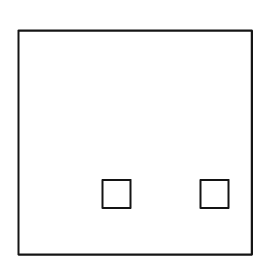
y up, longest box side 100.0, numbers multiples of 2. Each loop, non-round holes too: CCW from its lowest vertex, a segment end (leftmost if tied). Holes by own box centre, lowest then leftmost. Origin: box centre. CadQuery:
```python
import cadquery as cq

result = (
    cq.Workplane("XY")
    .moveTo(-50.0, -48.0)
    .lineTo(50.0, -48.0)
    .lineTo(50.0, 48.0)
    .lineTo(-50.0, 48.0)
    .close()
    .moveTo(-14.0, -28.0)
    .lineTo(-2.0, -28.0)
    .lineTo(-2.0, -16.0)
    .lineTo(-14.0, -16.0)
    .close()
    .moveTo(28.0, -28.0)
    .lineTo(40.0, -28.0)
    .lineTo(40.0, -16.0)
    .lineTo(28.0, -16.0)
    .close()
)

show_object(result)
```